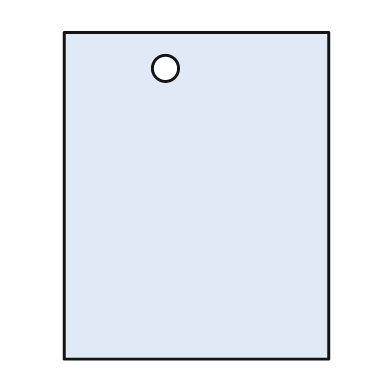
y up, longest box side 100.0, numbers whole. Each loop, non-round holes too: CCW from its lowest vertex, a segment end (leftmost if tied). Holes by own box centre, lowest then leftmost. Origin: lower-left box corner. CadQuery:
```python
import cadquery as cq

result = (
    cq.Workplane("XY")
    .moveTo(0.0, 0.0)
    .lineTo(81.0, 0.0)
    .lineTo(81.0, 100.0)
    .lineTo(0.0, 100.0)
    .close()
    .moveTo(31.0, 89.0)
    .circle(4.0)
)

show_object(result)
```